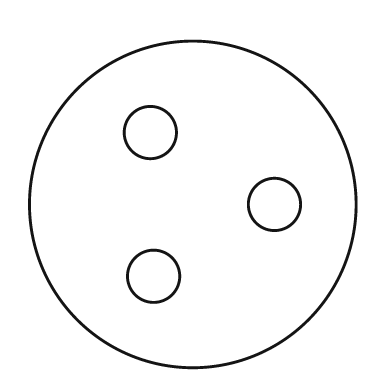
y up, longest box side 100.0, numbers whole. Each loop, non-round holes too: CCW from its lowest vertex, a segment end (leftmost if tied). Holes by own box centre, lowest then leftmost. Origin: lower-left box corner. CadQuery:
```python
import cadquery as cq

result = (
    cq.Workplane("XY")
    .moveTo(50.0, 50.0)
    .circle(50.0)
    .moveTo(38.0, 28.0)
    .circle(8.0)
    .moveTo(75.0, 50.0)
    .circle(8.0)
    .moveTo(37.0, 72.0)
    .circle(8.0)
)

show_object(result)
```